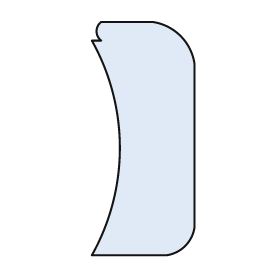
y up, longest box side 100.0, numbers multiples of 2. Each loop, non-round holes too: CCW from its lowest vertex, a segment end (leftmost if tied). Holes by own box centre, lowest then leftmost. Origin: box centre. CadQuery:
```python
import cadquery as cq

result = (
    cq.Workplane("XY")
    .moveTo(-22.0, -50.0)
    .lineTo(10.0, -50.0)
    .threePointArc((18.0, -46.0), (22.0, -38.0))
    .lineTo(22.0, 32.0)
    .threePointArc((16.0, 44.0), (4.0, 50.0))
    .lineTo(-18.0, 50.0)
    .threePointArc((-20.0, 46.0), (-18.0, 42.0))
    .lineTo(-22.0, 42.0)
    .threePointArc((-10.0, -4.0), (-22.0, -50.0))
    .close()
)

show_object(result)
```